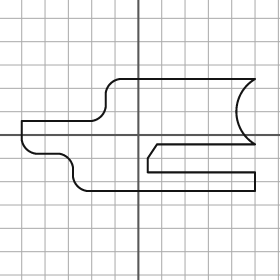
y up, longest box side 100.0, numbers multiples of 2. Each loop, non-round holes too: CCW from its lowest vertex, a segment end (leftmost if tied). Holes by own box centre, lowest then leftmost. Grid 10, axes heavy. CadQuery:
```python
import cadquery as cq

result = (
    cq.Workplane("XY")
    .moveTo(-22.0, -24.0)
    .lineTo(50.0, -24.0)
    .lineTo(50.0, -16.0)
    .lineTo(4.0, -16.0)
    .lineTo(4.0, -10.0)
    .lineTo(8.0, -4.0)
    .lineTo(50.0, -4.0)
    .threePointArc((42.0, 10.0), (50.0, 24.0))
    .lineTo(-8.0, 24.0)
    .threePointArc((-12.0, 22.0), (-14.0, 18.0))
    .lineTo(-14.0, 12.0)
    .threePointArc((-16.0, 8.0), (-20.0, 6.0))
    .lineTo(-50.0, 6.0)
    .lineTo(-50.0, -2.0)
    .threePointArc((-48.0, -6.0), (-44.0, -8.0))
    .lineTo(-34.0, -8.0)
    .threePointArc((-30.0, -10.0), (-28.0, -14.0))
    .lineTo(-28.0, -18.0)
    .threePointArc((-26.0, -22.0), (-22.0, -24.0))
    .close()
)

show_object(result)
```